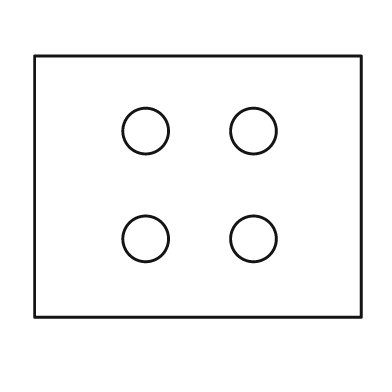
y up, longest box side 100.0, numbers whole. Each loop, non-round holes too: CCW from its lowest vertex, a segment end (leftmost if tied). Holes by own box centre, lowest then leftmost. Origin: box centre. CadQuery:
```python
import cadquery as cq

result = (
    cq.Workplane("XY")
    .moveTo(-50.0, -40.0)
    .lineTo(50.0, -40.0)
    .lineTo(50.0, 40.0)
    .lineTo(-50.0, 40.0)
    .close()
    .moveTo(-16.0, -16.0)
    .circle(7.0)
    .moveTo(17.0, -16.0)
    .circle(7.0)
    .moveTo(-16.0, 17.0)
    .circle(7.0)
    .moveTo(17.0, 17.0)
    .circle(7.0)
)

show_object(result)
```